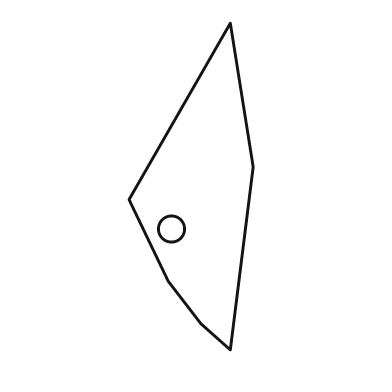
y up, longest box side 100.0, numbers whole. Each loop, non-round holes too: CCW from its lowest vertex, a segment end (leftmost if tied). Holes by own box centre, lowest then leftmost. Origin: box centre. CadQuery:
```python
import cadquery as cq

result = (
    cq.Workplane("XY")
    .moveTo(12.0, -50.0)
    .lineTo(19.0, 6.0)
    .lineTo(12.0, 50.0)
    .lineTo(-19.0, -4.0)
    .lineTo(-7.0, -29.0)
    .lineTo(3.0, -42.0)
    .close()
    .moveTo(-6.0, -13.0)
    .circle(4.0)
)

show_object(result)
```